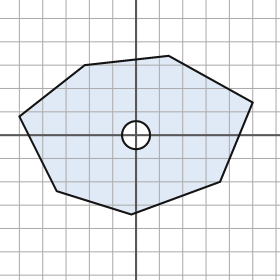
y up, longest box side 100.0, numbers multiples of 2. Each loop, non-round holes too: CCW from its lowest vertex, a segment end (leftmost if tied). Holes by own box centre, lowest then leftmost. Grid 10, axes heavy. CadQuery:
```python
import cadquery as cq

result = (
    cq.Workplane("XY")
    .moveTo(-2.0, -34.0)
    .lineTo(36.0, -20.0)
    .lineTo(50.0, 14.0)
    .lineTo(14.0, 34.0)
    .lineTo(-22.0, 30.0)
    .lineTo(-50.0, 8.0)
    .lineTo(-34.0, -24.0)
    .close()
    .moveTo(0.0, 0.0)
    .circle(6.0)
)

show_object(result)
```